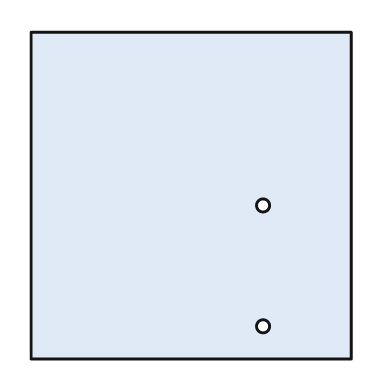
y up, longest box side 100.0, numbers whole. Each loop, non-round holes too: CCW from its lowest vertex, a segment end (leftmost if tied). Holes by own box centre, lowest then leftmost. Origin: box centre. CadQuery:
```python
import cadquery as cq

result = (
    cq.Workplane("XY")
    .moveTo(-49.0, -50.0)
    .lineTo(49.0, -50.0)
    .lineTo(49.0, 50.0)
    .lineTo(-49.0, 50.0)
    .close()
    .moveTo(22.0, -40.0)
    .circle(2.0)
    .moveTo(22.0, -3.0)
    .circle(2.0)
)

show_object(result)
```